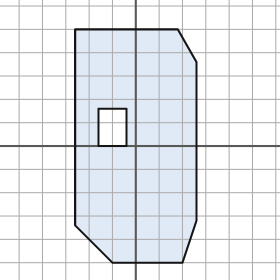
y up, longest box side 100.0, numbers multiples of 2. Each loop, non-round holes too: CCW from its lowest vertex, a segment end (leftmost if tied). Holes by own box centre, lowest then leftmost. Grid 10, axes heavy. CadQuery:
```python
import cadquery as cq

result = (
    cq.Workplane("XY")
    .moveTo(-10.0, -50.0)
    .lineTo(20.0, -50.0)
    .lineTo(26.0, -32.0)
    .lineTo(26.0, 36.0)
    .lineTo(18.0, 50.0)
    .lineTo(-26.0, 50.0)
    .lineTo(-26.0, -34.0)
    .close()
    .moveTo(-16.0, 0.0)
    .lineTo(-4.0, 0.0)
    .lineTo(-4.0, 16.0)
    .lineTo(-16.0, 16.0)
    .close()
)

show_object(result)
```